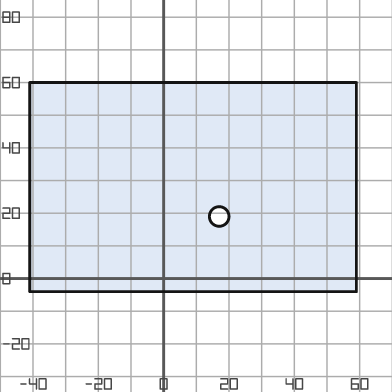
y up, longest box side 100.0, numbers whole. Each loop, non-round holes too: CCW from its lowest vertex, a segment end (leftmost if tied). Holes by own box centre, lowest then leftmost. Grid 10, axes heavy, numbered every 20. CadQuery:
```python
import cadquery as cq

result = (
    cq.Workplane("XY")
    .moveTo(-41.0, -4.0)
    .lineTo(59.0, -4.0)
    .lineTo(59.0, 60.0)
    .lineTo(-41.0, 60.0)
    .close()
    .moveTo(17.0, 19.0)
    .circle(3.0)
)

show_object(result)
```